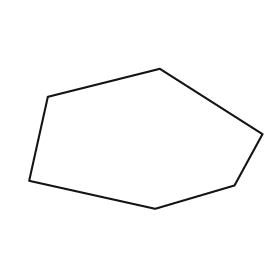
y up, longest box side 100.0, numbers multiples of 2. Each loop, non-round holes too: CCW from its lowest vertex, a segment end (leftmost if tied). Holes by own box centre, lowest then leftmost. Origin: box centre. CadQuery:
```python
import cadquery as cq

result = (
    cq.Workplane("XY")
    .moveTo(4.0, -30.0)
    .lineTo(38.0, -20.0)
    .lineTo(50.0, 2.0)
    .lineTo(6.0, 30.0)
    .lineTo(-42.0, 18.0)
    .lineTo(-50.0, -18.0)
    .close()
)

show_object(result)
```